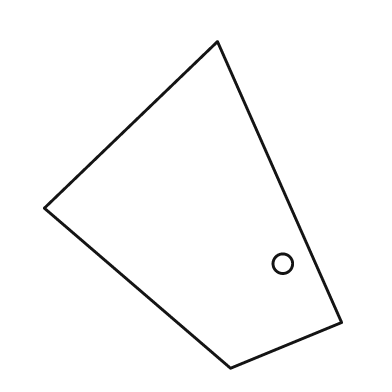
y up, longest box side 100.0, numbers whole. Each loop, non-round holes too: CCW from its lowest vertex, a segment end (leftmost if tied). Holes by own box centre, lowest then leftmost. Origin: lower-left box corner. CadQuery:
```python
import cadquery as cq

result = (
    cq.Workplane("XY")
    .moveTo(57.0, 0.0)
    .lineTo(91.0, 14.0)
    .lineTo(53.0, 100.0)
    .lineTo(0.0, 49.0)
    .close()
    .moveTo(73.0, 32.0)
    .circle(3.0)
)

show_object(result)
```